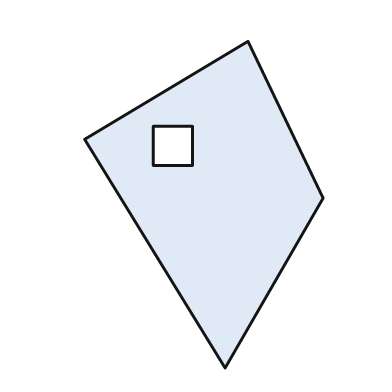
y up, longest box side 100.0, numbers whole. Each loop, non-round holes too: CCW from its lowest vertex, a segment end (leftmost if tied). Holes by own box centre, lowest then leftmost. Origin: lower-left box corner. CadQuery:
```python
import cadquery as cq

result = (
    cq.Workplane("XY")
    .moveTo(43.0, 0.0)
    .lineTo(73.0, 52.0)
    .lineTo(50.0, 100.0)
    .lineTo(0.0, 70.0)
    .close()
    .moveTo(21.0, 62.0)
    .lineTo(33.0, 62.0)
    .lineTo(33.0, 74.0)
    .lineTo(21.0, 74.0)
    .close()
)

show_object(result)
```